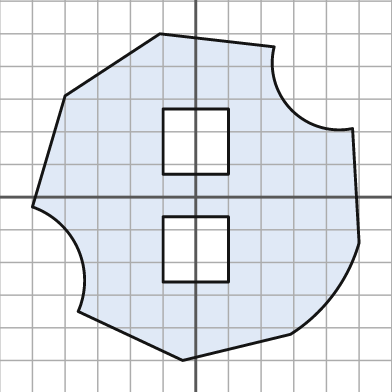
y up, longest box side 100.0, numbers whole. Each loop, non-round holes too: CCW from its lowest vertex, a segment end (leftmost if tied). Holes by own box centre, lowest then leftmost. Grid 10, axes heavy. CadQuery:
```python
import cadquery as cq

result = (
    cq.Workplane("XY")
    .moveTo(-4.0, -50.0)
    .lineTo(29.0, -42.0)
    .threePointArc((42.0, -30.0), (50.0, -14.0))
    .lineTo(48.0, 21.0)
    .threePointArc((29.0, 27.0), (24.0, 46.0))
    .lineTo(-11.0, 50.0)
    .lineTo(-40.0, 31.0)
    .lineTo(-50.0, -3.0)
    .threePointArc((-36.0, -16.0), (-36.0, -35.0))
    .close()
    .moveTo(-10.0, -26.0)
    .lineTo(10.0, -26.0)
    .lineTo(10.0, -6.0)
    .lineTo(-10.0, -6.0)
    .close()
    .moveTo(-10.0, 7.0)
    .lineTo(10.0, 7.0)
    .lineTo(10.0, 27.0)
    .lineTo(-10.0, 27.0)
    .close()
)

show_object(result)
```